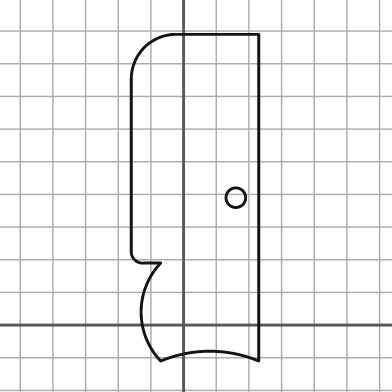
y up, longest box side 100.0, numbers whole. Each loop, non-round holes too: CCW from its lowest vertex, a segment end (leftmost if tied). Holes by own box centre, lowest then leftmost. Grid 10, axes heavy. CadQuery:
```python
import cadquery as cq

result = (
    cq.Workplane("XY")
    .moveTo(-7.0, -11.0)
    .threePointArc((8.0, -8.0), (23.0, -11.0))
    .lineTo(23.0, 89.0)
    .lineTo(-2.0, 89.0)
    .threePointArc((-12.0, 85.0), (-16.0, 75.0))
    .lineTo(-16.0, 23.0)
    .threePointArc((-15.0, 20.0), (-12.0, 19.0))
    .lineTo(-7.0, 19.0)
    .threePointArc((-13.0, 4.0), (-7.0, -11.0))
    .close()
    .moveTo(16.0, 39.0)
    .circle(3.0)
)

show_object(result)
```